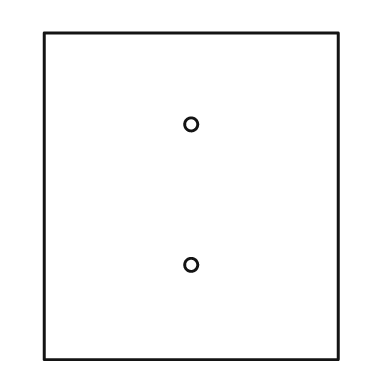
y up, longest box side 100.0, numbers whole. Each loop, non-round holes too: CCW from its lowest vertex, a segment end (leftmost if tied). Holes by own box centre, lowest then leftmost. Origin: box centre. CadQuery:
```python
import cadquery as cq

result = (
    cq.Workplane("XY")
    .moveTo(-45.0, -50.0)
    .lineTo(45.0, -50.0)
    .lineTo(45.0, 50.0)
    .lineTo(-45.0, 50.0)
    .close()
    .moveTo(0.0, -21.0)
    .circle(2.0)
    .moveTo(0.0, 22.0)
    .circle(2.0)
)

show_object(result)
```